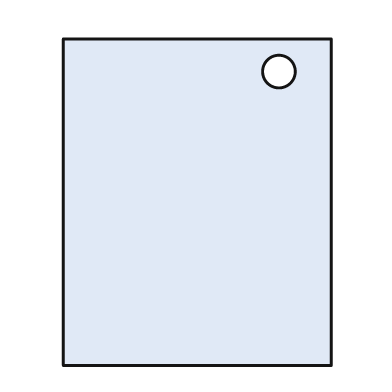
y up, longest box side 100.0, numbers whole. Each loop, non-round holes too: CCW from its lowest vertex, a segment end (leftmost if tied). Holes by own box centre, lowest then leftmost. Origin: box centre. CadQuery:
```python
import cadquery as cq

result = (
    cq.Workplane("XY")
    .moveTo(-41.0, -50.0)
    .lineTo(41.0, -50.0)
    .lineTo(41.0, 50.0)
    .lineTo(-41.0, 50.0)
    .close()
    .moveTo(25.0, 40.0)
    .circle(5.0)
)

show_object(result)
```